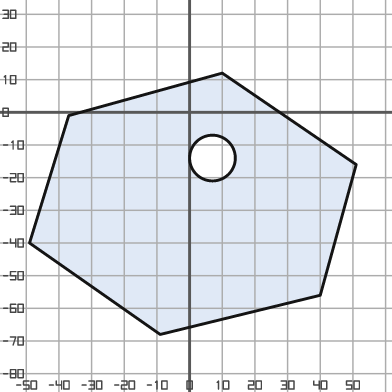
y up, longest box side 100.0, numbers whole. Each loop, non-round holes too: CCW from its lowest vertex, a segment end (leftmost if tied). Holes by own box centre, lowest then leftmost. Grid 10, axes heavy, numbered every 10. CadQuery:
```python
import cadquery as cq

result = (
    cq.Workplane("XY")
    .moveTo(-9.0, -68.0)
    .lineTo(40.0, -56.0)
    .lineTo(51.0, -16.0)
    .lineTo(10.0, 12.0)
    .lineTo(-37.0, -1.0)
    .lineTo(-49.0, -40.0)
    .close()
    .moveTo(7.0, -14.0)
    .circle(7.0)
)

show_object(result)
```